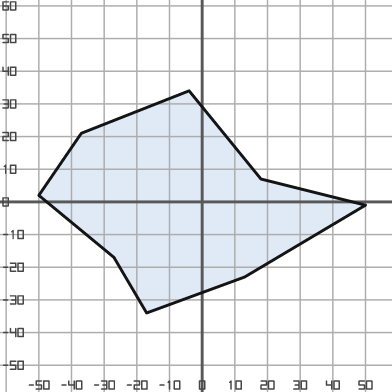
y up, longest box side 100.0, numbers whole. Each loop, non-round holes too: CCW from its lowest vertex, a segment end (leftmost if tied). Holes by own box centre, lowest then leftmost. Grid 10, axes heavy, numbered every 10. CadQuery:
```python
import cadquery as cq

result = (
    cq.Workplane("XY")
    .moveTo(-17.0, -34.0)
    .lineTo(13.0, -23.0)
    .lineTo(50.0, -1.0)
    .lineTo(18.0, 7.0)
    .lineTo(-4.0, 34.0)
    .lineTo(-37.0, 21.0)
    .lineTo(-50.0, 2.0)
    .lineTo(-27.0, -17.0)
    .close()
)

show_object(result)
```